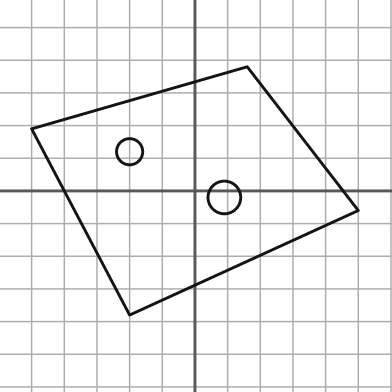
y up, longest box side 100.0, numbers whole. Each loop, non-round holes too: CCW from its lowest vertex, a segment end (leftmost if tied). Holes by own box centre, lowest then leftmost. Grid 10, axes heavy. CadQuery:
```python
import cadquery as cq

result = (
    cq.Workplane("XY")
    .moveTo(-20.0, -38.0)
    .lineTo(50.0, -6.0)
    .lineTo(16.0, 38.0)
    .lineTo(-50.0, 19.0)
    .close()
    .moveTo(9.0, -2.0)
    .circle(5.0)
    .moveTo(-20.0, 12.0)
    .circle(4.0)
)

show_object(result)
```